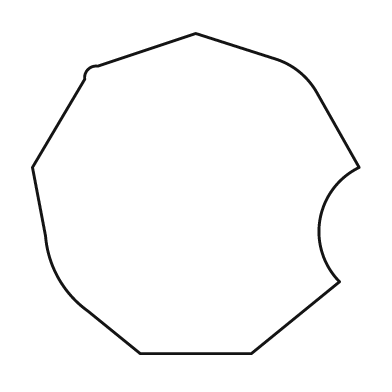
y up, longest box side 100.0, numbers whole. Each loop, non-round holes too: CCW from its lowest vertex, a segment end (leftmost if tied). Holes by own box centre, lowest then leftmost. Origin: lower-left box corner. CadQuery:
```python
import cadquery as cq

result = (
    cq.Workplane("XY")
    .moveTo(33.0, 0.0)
    .lineTo(67.0, 0.0)
    .lineTo(94.0, 22.0)
    .threePointArc((88.0, 41.0), (100.0, 57.0))
    .lineTo(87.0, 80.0)
    .threePointArc((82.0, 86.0), (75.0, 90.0))
    .lineTo(50.0, 98.0)
    .lineTo(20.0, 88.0)
    .threePointArc((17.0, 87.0), (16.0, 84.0))
    .lineTo(0.0, 57.0)
    .lineTo(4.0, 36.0)
    .threePointArc((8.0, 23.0), (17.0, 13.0))
    .close()
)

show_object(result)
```